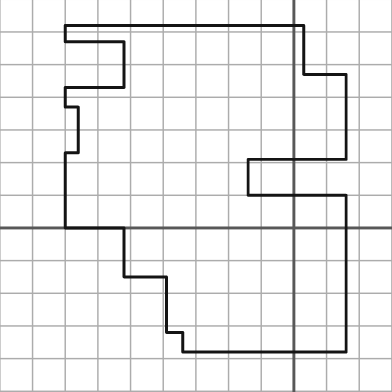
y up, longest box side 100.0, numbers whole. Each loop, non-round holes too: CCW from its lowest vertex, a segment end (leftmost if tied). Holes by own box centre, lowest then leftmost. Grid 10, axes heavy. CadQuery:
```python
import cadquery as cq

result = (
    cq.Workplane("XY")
    .moveTo(-34.0, -38.0)
    .lineTo(16.0, -38.0)
    .lineTo(16.0, 10.0)
    .lineTo(-14.0, 10.0)
    .lineTo(-14.0, 21.0)
    .lineTo(16.0, 21.0)
    .lineTo(16.0, 47.0)
    .lineTo(3.0, 47.0)
    .lineTo(3.0, 62.0)
    .lineTo(-70.0, 62.0)
    .lineTo(-70.0, 57.0)
    .lineTo(-52.0, 57.0)
    .lineTo(-52.0, 43.0)
    .lineTo(-70.0, 43.0)
    .lineTo(-70.0, 37.0)
    .lineTo(-66.0, 37.0)
    .lineTo(-66.0, 23.0)
    .lineTo(-70.0, 23.0)
    .lineTo(-70.0, 0.0)
    .lineTo(-52.0, 0.0)
    .lineTo(-52.0, -15.0)
    .lineTo(-39.0, -15.0)
    .lineTo(-39.0, -32.0)
    .lineTo(-34.0, -32.0)
    .close()
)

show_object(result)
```